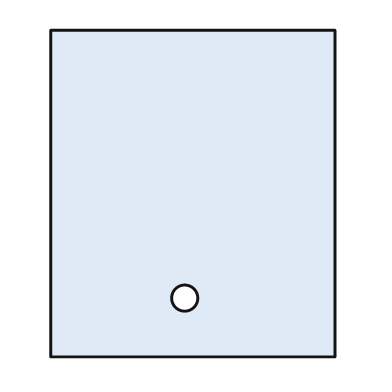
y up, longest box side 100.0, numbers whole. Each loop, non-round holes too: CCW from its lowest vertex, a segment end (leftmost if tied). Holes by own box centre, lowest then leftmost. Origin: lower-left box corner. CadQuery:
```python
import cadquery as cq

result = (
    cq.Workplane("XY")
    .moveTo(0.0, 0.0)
    .lineTo(87.0, 0.0)
    .lineTo(87.0, 100.0)
    .lineTo(0.0, 100.0)
    .close()
    .moveTo(41.0, 18.0)
    .circle(4.0)
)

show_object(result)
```